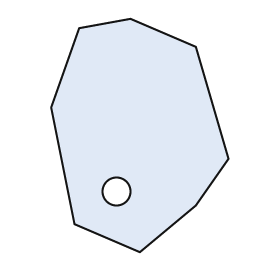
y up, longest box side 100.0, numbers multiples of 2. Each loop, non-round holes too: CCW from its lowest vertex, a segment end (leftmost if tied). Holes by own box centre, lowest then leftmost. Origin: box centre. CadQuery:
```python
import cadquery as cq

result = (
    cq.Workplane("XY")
    .moveTo(0.0, -50.0)
    .lineTo(24.0, -30.0)
    .lineTo(38.0, -10.0)
    .lineTo(24.0, 38.0)
    .lineTo(-4.0, 50.0)
    .lineTo(-26.0, 46.0)
    .lineTo(-38.0, 12.0)
    .lineTo(-28.0, -38.0)
    .close()
    .moveTo(-10.0, -24.0)
    .circle(6.0)
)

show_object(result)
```